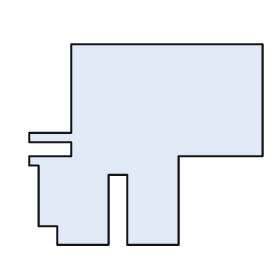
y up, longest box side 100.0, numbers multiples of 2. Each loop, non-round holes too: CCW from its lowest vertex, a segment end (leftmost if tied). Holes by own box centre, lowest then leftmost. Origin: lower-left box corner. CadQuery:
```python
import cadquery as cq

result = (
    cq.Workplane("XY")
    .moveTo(12.0, 0.0)
    .lineTo(34.0, 0.0)
    .lineTo(34.0, 30.0)
    .lineTo(42.0, 30.0)
    .lineTo(42.0, 0.0)
    .lineTo(64.0, 0.0)
    .lineTo(64.0, 38.0)
    .lineTo(100.0, 38.0)
    .lineTo(100.0, 86.0)
    .lineTo(18.0, 86.0)
    .lineTo(18.0, 48.0)
    .lineTo(0.0, 48.0)
    .lineTo(0.0, 44.0)
    .lineTo(18.0, 44.0)
    .lineTo(18.0, 38.0)
    .lineTo(0.0, 38.0)
    .lineTo(0.0, 34.0)
    .lineTo(4.0, 34.0)
    .lineTo(4.0, 8.0)
    .lineTo(12.0, 8.0)
    .close()
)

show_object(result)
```